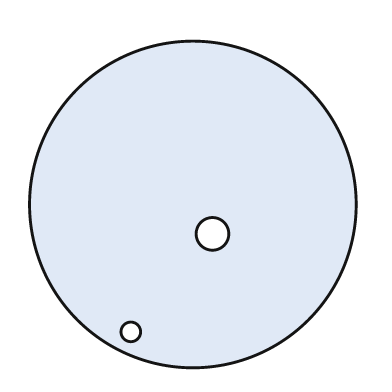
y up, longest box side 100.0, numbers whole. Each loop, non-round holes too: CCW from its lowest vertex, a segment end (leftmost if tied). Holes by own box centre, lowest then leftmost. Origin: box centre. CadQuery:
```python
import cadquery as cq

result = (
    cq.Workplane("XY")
    .moveTo(0.0, 0.0)
    .circle(50.0)
    .moveTo(-19.0, -39.0)
    .circle(3.0)
    .moveTo(6.0, -9.0)
    .circle(5.0)
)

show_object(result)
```